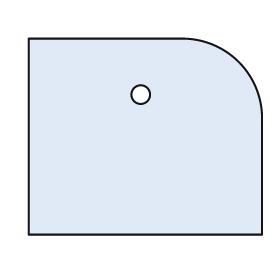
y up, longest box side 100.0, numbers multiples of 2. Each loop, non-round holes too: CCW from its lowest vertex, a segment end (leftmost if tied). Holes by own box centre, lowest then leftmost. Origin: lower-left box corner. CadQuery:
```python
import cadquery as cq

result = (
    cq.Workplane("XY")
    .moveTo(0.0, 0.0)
    .lineTo(100.0, 0.0)
    .lineTo(100.0, 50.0)
    .threePointArc((90.0, 74.0), (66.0, 84.0))
    .lineTo(0.0, 84.0)
    .close()
    .moveTo(48.0, 60.0)
    .circle(4.0)
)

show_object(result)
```